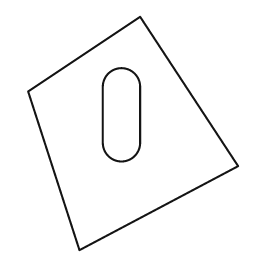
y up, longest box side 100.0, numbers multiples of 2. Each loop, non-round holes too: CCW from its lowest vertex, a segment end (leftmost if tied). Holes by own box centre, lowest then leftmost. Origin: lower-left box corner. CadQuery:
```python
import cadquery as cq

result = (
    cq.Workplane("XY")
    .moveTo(22.0, 0.0)
    .lineTo(90.0, 36.0)
    .lineTo(48.0, 100.0)
    .lineTo(0.0, 68.0)
    .close()
    .moveTo(32.0, 46.0)
    .threePointArc((40.0, 38.0), (48.0, 46.0))
    .lineTo(48.0, 70.0)
    .threePointArc((40.0, 78.0), (32.0, 70.0))
    .close()
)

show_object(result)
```